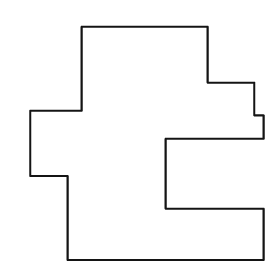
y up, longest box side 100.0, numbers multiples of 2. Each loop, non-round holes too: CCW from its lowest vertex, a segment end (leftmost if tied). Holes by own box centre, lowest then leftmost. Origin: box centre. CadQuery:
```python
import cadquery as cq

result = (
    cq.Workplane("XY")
    .moveTo(-34.0, -50.0)
    .lineTo(50.0, -50.0)
    .lineTo(50.0, -28.0)
    .lineTo(8.0, -28.0)
    .lineTo(8.0, 2.0)
    .lineTo(50.0, 2.0)
    .lineTo(50.0, 12.0)
    .lineTo(46.0, 12.0)
    .lineTo(46.0, 26.0)
    .lineTo(26.0, 26.0)
    .lineTo(26.0, 50.0)
    .lineTo(-28.0, 50.0)
    .lineTo(-28.0, 14.0)
    .lineTo(-50.0, 14.0)
    .lineTo(-50.0, -14.0)
    .lineTo(-34.0, -14.0)
    .close()
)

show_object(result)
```